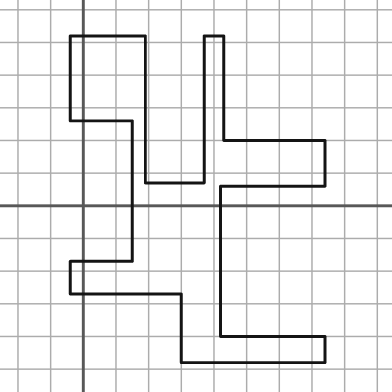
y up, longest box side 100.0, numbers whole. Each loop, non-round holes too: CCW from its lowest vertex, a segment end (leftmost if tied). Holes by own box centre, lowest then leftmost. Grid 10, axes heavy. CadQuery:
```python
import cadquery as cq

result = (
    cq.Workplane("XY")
    .moveTo(30.0, -48.0)
    .lineTo(74.0, -48.0)
    .lineTo(74.0, -40.0)
    .lineTo(42.0, -40.0)
    .lineTo(42.0, 6.0)
    .lineTo(74.0, 6.0)
    .lineTo(74.0, 20.0)
    .lineTo(43.0, 20.0)
    .lineTo(43.0, 52.0)
    .lineTo(37.0, 52.0)
    .lineTo(37.0, 7.0)
    .lineTo(19.0, 7.0)
    .lineTo(19.0, 52.0)
    .lineTo(-4.0, 52.0)
    .lineTo(-4.0, 26.0)
    .lineTo(15.0, 26.0)
    .lineTo(15.0, -17.0)
    .lineTo(-4.0, -17.0)
    .lineTo(-4.0, -27.0)
    .lineTo(30.0, -27.0)
    .close()
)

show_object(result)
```